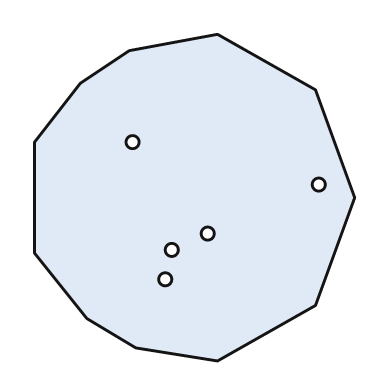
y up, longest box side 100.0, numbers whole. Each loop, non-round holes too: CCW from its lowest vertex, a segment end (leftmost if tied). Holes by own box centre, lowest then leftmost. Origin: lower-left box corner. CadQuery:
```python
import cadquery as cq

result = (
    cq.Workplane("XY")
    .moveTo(56.0, 0.0)
    .lineTo(86.0, 17.0)
    .lineTo(98.0, 50.0)
    .lineTo(86.0, 83.0)
    .lineTo(56.0, 100.0)
    .lineTo(29.0, 95.0)
    .lineTo(14.0, 85.0)
    .lineTo(0.0, 67.0)
    .lineTo(0.0, 33.0)
    .lineTo(16.0, 13.0)
    .lineTo(31.0, 4.0)
    .close()
    .moveTo(40.0, 25.0)
    .circle(2.0)
    .moveTo(42.0, 34.0)
    .circle(2.0)
    .moveTo(53.0, 39.0)
    .circle(2.0)
    .moveTo(87.0, 54.0)
    .circle(2.0)
    .moveTo(30.0, 67.0)
    .circle(2.0)
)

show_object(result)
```